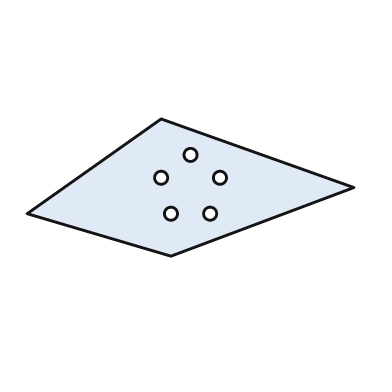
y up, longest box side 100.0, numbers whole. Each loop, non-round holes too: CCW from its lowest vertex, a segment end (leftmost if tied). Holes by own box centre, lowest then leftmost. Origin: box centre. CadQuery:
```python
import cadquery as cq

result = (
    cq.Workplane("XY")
    .moveTo(-6.0, -21.0)
    .lineTo(50.0, 0.0)
    .lineTo(-9.0, 21.0)
    .lineTo(-50.0, -8.0)
    .close()
    .moveTo(-6.0, -8.0)
    .circle(2.0)
    .moveTo(6.0, -8.0)
    .circle(2.0)
    .moveTo(-9.0, 3.0)
    .circle(2.0)
    .moveTo(9.0, 3.0)
    .circle(2.0)
    .moveTo(0.0, 10.0)
    .circle(2.0)
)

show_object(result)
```